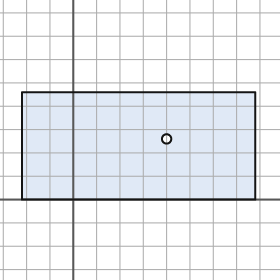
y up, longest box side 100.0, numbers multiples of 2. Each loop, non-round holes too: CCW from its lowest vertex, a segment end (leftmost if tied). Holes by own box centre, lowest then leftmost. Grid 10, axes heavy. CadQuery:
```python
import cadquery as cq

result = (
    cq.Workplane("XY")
    .moveTo(-22.0, 0.0)
    .lineTo(78.0, 0.0)
    .lineTo(78.0, 46.0)
    .lineTo(-22.0, 46.0)
    .close()
    .moveTo(40.0, 26.0)
    .circle(2.0)
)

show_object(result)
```